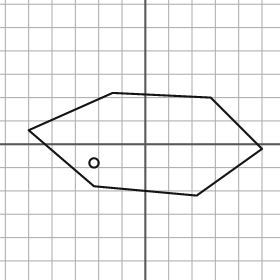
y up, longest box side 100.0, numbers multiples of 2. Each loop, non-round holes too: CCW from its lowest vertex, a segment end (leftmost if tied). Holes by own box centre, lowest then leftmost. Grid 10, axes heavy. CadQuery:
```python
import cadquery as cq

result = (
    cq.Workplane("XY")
    .moveTo(22.0, -22.0)
    .lineTo(50.0, -2.0)
    .lineTo(28.0, 20.0)
    .lineTo(-14.0, 22.0)
    .lineTo(-50.0, 6.0)
    .lineTo(-22.0, -18.0)
    .close()
    .moveTo(-22.0, -8.0)
    .circle(2.0)
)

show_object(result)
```